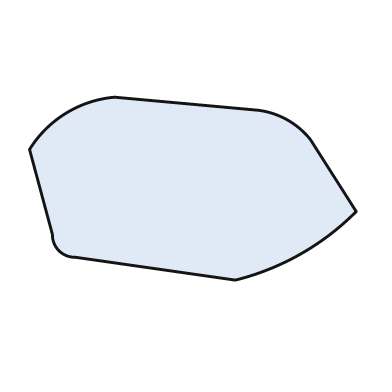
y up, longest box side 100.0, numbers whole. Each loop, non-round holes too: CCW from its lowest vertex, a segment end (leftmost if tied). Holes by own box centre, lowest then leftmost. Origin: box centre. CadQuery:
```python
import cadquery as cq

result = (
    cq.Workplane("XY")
    .moveTo(13.0, -28.0)
    .threePointArc((33.0, -20.0), (50.0, -7.0))
    .lineTo(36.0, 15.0)
    .threePointArc((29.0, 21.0), (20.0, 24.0))
    .lineTo(-24.0, 28.0)
    .threePointArc((-39.0, 23.0), (-50.0, 12.0))
    .lineTo(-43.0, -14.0)
    .threePointArc((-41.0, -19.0), (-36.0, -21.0))
    .close()
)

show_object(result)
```